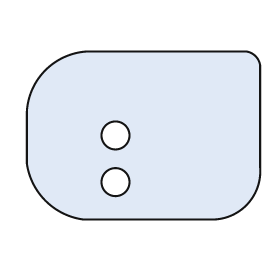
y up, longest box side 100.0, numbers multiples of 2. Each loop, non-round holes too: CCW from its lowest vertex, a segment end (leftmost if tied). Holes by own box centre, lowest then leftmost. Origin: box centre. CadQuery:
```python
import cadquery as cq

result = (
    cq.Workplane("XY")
    .moveTo(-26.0, -36.0)
    .lineTo(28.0, -36.0)
    .threePointArc((44.0, -30.0), (50.0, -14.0))
    .lineTo(50.0, 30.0)
    .threePointArc((48.0, 34.0), (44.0, 36.0))
    .lineTo(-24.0, 36.0)
    .threePointArc((-42.0, 28.0), (-50.0, 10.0))
    .lineTo(-50.0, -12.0)
    .threePointArc((-42.0, -28.0), (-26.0, -36.0))
    .close()
    .moveTo(-12.0, -20.0)
    .circle(6.0)
    .moveTo(-12.0, 0.0)
    .circle(6.0)
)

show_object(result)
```